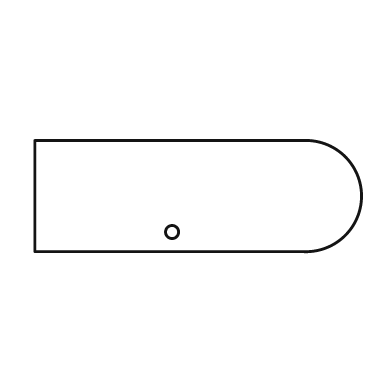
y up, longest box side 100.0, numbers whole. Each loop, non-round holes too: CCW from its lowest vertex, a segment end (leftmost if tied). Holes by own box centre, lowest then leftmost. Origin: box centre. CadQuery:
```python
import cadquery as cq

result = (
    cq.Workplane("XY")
    .moveTo(-50.0, -17.0)
    .lineTo(32.0, -17.0)
    .threePointArc((50.0, 0.0), (32.0, 17.0))
    .lineTo(-50.0, 17.0)
    .close()
    .moveTo(-8.0, -11.0)
    .circle(2.0)
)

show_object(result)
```